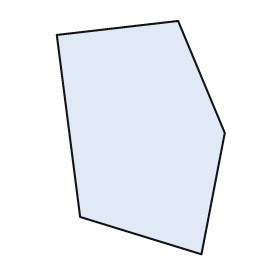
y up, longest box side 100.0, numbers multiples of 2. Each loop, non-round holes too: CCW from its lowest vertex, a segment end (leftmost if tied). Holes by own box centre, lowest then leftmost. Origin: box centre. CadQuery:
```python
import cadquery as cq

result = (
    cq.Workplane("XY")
    .moveTo(26.0, -50.0)
    .lineTo(36.0, 2.0)
    .lineTo(16.0, 50.0)
    .lineTo(-36.0, 44.0)
    .lineTo(-26.0, -34.0)
    .close()
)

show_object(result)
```